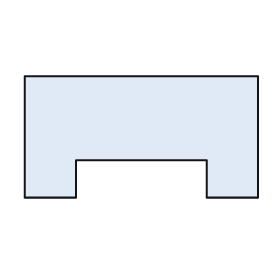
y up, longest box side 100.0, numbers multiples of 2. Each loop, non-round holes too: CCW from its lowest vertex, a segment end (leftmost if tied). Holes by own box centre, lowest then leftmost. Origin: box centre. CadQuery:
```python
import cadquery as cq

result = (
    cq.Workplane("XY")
    .moveTo(-50.0, -26.0)
    .lineTo(-28.0, -26.0)
    .lineTo(-28.0, -10.0)
    .lineTo(28.0, -10.0)
    .lineTo(28.0, -26.0)
    .lineTo(50.0, -26.0)
    .lineTo(50.0, 26.0)
    .lineTo(-50.0, 26.0)
    .close()
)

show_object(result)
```